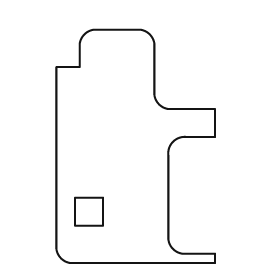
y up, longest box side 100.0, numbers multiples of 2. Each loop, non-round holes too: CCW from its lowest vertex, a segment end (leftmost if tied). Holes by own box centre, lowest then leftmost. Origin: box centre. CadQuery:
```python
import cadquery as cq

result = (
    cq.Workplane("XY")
    .moveTo(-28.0, -50.0)
    .lineTo(34.0, -50.0)
    .lineTo(34.0, -46.0)
    .lineTo(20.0, -46.0)
    .threePointArc((16.0, -44.0), (14.0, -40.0))
    .lineTo(14.0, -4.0)
    .threePointArc((16.0, 2.0), (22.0, 4.0))
    .lineTo(34.0, 4.0)
    .lineTo(34.0, 16.0)
    .lineTo(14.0, 16.0)
    .threePointArc((10.0, 18.0), (8.0, 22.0))
    .lineTo(8.0, 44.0)
    .threePointArc((6.0, 48.0), (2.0, 50.0))
    .lineTo(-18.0, 50.0)
    .threePointArc((-22.0, 48.0), (-24.0, 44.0))
    .lineTo(-24.0, 34.0)
    .lineTo(-34.0, 34.0)
    .lineTo(-34.0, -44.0)
    .threePointArc((-32.0, -48.0), (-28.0, -50.0))
    .close()
    .moveTo(-26.0, -34.0)
    .lineTo(-14.0, -34.0)
    .lineTo(-14.0, -22.0)
    .lineTo(-26.0, -22.0)
    .close()
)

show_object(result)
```